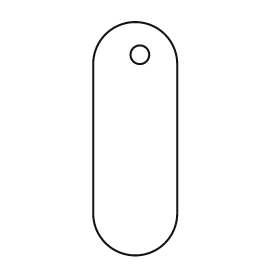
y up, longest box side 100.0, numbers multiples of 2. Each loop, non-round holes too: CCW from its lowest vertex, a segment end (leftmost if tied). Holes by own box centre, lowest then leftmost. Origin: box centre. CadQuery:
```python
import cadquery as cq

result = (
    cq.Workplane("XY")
    .moveTo(-18.0, -32.0)
    .threePointArc((0.0, -50.0), (18.0, -32.0))
    .lineTo(18.0, 32.0)
    .threePointArc((0.0, 50.0), (-18.0, 32.0))
    .close()
    .moveTo(2.0, 36.0)
    .circle(4.0)
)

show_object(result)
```